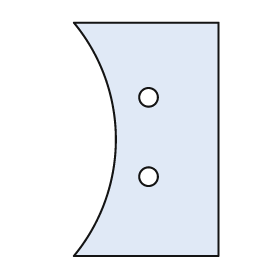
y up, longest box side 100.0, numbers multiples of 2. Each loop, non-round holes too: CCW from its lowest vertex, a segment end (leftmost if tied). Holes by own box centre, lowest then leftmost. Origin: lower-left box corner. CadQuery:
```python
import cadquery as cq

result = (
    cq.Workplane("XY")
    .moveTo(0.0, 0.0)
    .lineTo(62.0, 0.0)
    .lineTo(62.0, 100.0)
    .lineTo(0.0, 100.0)
    .threePointArc((18.0, 50.0), (0.0, 0.0))
    .close()
    .moveTo(32.0, 34.0)
    .circle(4.0)
    .moveTo(32.0, 68.0)
    .circle(4.0)
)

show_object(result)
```